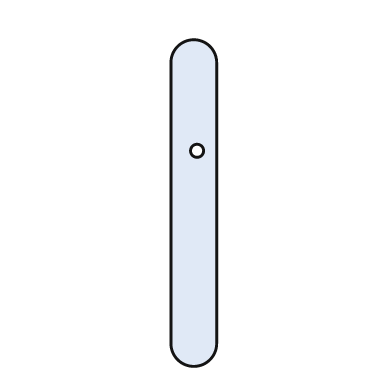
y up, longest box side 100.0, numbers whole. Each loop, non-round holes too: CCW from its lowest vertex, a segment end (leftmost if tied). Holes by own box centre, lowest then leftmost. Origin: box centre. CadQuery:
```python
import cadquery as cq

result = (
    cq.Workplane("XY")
    .moveTo(-7.0, -43.0)
    .threePointArc((0.0, -50.0), (7.0, -43.0))
    .lineTo(7.0, 43.0)
    .threePointArc((0.0, 50.0), (-7.0, 43.0))
    .close()
    .moveTo(1.0, 16.0)
    .circle(2.0)
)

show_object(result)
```